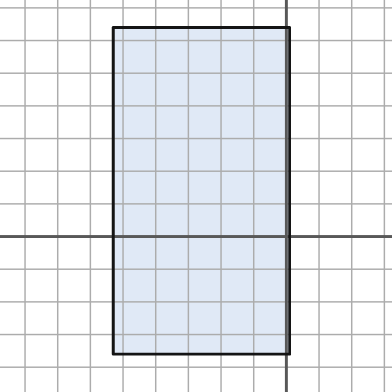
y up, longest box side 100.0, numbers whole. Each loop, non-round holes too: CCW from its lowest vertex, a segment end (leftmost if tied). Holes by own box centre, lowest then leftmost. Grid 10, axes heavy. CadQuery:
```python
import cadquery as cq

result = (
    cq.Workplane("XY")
    .moveTo(-53.0, -36.0)
    .lineTo(1.0, -36.0)
    .lineTo(1.0, 64.0)
    .lineTo(-53.0, 64.0)
    .close()
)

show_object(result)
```